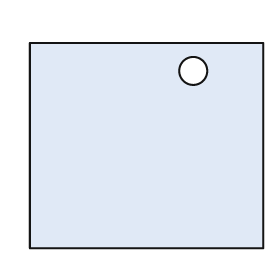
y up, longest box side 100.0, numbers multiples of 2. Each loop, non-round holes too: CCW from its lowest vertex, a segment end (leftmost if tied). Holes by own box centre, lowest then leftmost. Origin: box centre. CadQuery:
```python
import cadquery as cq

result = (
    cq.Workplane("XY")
    .moveTo(-50.0, -44.0)
    .lineTo(50.0, -44.0)
    .lineTo(50.0, 44.0)
    .lineTo(-50.0, 44.0)
    .close()
    .moveTo(20.0, 32.0)
    .circle(6.0)
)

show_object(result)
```